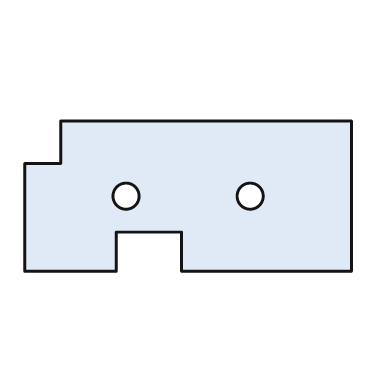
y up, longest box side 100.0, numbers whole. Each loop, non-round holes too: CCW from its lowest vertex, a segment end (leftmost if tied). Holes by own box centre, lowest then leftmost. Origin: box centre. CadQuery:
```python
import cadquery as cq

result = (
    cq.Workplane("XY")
    .moveTo(-50.0, -23.0)
    .lineTo(-22.0, -23.0)
    .lineTo(-22.0, -11.0)
    .lineTo(-2.0, -11.0)
    .lineTo(-2.0, -23.0)
    .lineTo(50.0, -23.0)
    .lineTo(50.0, 23.0)
    .lineTo(-39.0, 23.0)
    .lineTo(-39.0, 10.0)
    .lineTo(-50.0, 10.0)
    .close()
    .moveTo(-19.0, 0.0)
    .circle(4.0)
    .moveTo(19.0, 0.0)
    .circle(4.0)
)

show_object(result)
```